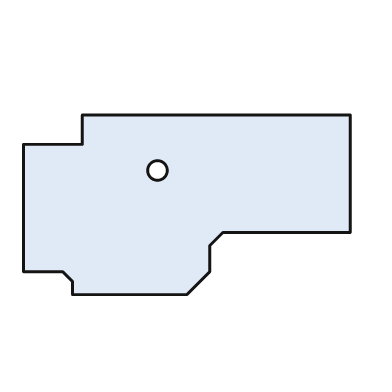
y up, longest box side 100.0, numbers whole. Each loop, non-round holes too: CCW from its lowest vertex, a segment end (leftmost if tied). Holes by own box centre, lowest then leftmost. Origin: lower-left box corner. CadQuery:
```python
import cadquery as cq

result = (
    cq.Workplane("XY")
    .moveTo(15.0, 0.0)
    .lineTo(50.0, 0.0)
    .lineTo(57.0, 7.0)
    .lineTo(57.0, 15.0)
    .lineTo(61.0, 19.0)
    .lineTo(100.0, 19.0)
    .lineTo(100.0, 55.0)
    .lineTo(18.0, 55.0)
    .lineTo(18.0, 46.0)
    .lineTo(0.0, 46.0)
    .lineTo(0.0, 7.0)
    .lineTo(12.0, 7.0)
    .lineTo(15.0, 4.0)
    .close()
    .moveTo(41.0, 38.0)
    .circle(3.0)
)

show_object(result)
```